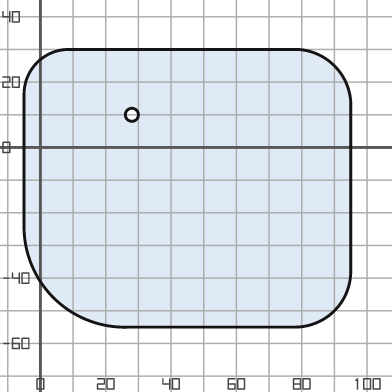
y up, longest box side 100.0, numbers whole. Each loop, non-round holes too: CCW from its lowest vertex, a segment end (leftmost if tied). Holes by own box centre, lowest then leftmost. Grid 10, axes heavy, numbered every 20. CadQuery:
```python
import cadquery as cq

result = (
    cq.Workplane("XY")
    .moveTo(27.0, -55.0)
    .lineTo(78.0, -55.0)
    .threePointArc((90.0, -50.0), (95.0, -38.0))
    .lineTo(95.0, 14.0)
    .threePointArc((90.0, 25.0), (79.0, 30.0))
    .lineTo(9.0, 30.0)
    .threePointArc((-1.0, 26.0), (-5.0, 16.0))
    .lineTo(-5.0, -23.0)
    .threePointArc((4.0, -46.0), (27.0, -55.0))
    .close()
    .moveTo(28.0, 10.0)
    .circle(2.0)
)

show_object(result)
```